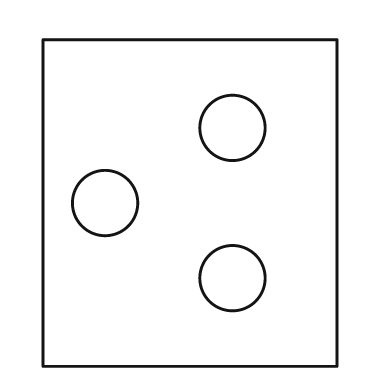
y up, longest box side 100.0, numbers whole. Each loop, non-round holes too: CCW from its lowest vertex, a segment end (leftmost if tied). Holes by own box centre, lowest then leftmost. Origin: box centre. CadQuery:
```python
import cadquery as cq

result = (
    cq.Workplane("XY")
    .moveTo(-45.0, -50.0)
    .lineTo(45.0, -50.0)
    .lineTo(45.0, 50.0)
    .lineTo(-45.0, 50.0)
    .close()
    .moveTo(13.0, -23.0)
    .circle(10.0)
    .moveTo(-26.0, 0.0)
    .circle(10.0)
    .moveTo(13.0, 23.0)
    .circle(10.0)
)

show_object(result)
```